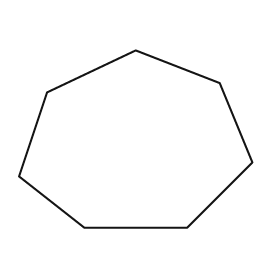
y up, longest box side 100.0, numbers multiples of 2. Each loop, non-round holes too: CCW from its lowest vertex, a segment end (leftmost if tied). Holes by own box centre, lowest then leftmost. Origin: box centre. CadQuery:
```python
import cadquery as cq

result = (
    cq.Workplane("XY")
    .moveTo(-22.0, -38.0)
    .lineTo(22.0, -38.0)
    .lineTo(50.0, -10.0)
    .lineTo(36.0, 24.0)
    .lineTo(0.0, 38.0)
    .lineTo(-38.0, 20.0)
    .lineTo(-50.0, -16.0)
    .close()
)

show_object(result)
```